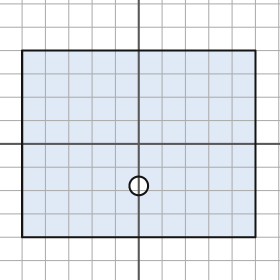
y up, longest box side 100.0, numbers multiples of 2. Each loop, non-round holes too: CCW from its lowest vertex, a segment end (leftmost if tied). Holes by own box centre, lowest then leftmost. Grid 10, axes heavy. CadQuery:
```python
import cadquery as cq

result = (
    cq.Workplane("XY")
    .moveTo(-50.0, -40.0)
    .lineTo(50.0, -40.0)
    .lineTo(50.0, 40.0)
    .lineTo(-50.0, 40.0)
    .close()
    .moveTo(0.0, -18.0)
    .circle(4.0)
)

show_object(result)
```